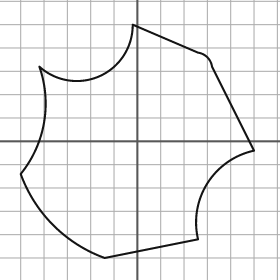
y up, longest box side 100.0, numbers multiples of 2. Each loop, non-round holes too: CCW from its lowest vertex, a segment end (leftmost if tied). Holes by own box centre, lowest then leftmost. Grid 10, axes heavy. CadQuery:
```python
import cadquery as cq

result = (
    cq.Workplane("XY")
    .moveTo(-14.0, -50.0)
    .lineTo(26.0, -42.0)
    .threePointArc((30.0, -18.0), (50.0, -4.0))
    .lineTo(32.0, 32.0)
    .threePointArc((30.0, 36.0), (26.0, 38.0))
    .lineTo(-2.0, 50.0)
    .threePointArc((-16.0, 28.0), (-42.0, 32.0))
    .threePointArc((-40.0, 8.0), (-50.0, -14.0))
    .threePointArc((-36.0, -36.0), (-14.0, -50.0))
    .close()
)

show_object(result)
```